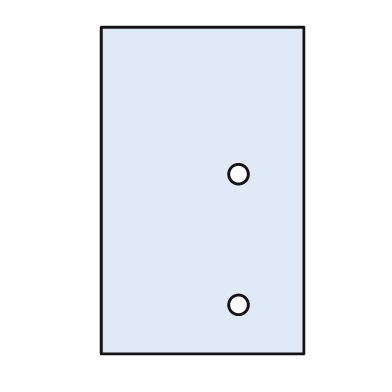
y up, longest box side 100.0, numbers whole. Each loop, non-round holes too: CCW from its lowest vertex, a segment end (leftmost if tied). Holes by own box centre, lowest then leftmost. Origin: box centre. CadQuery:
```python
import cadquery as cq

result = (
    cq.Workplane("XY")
    .moveTo(-31.0, -50.0)
    .lineTo(31.0, -50.0)
    .lineTo(31.0, 50.0)
    .lineTo(-31.0, 50.0)
    .close()
    .moveTo(11.0, -35.0)
    .circle(3.0)
    .moveTo(11.0, 5.0)
    .circle(3.0)
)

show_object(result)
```